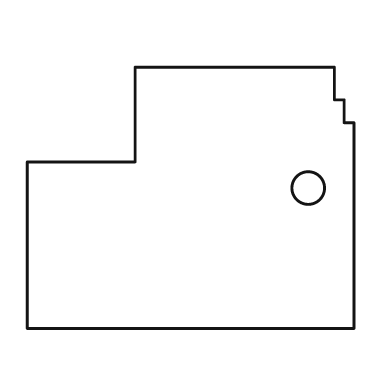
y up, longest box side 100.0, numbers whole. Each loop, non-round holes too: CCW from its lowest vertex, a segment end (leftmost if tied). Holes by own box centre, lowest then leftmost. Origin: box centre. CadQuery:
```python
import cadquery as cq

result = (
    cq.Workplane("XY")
    .moveTo(-50.0, -40.0)
    .lineTo(50.0, -40.0)
    .lineTo(50.0, 23.0)
    .lineTo(47.0, 23.0)
    .lineTo(47.0, 30.0)
    .lineTo(44.0, 30.0)
    .lineTo(44.0, 40.0)
    .lineTo(-17.0, 40.0)
    .lineTo(-17.0, 11.0)
    .lineTo(-50.0, 11.0)
    .close()
    .moveTo(36.0, 3.0)
    .circle(5.0)
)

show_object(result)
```